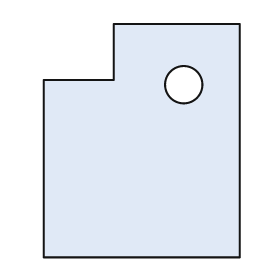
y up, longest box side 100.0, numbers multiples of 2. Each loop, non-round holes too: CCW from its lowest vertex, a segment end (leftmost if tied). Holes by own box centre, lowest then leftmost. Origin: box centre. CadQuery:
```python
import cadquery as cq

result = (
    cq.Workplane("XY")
    .moveTo(-42.0, -50.0)
    .lineTo(42.0, -50.0)
    .lineTo(42.0, 50.0)
    .lineTo(-12.0, 50.0)
    .lineTo(-12.0, 26.0)
    .lineTo(-42.0, 26.0)
    .close()
    .moveTo(18.0, 24.0)
    .circle(8.0)
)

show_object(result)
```